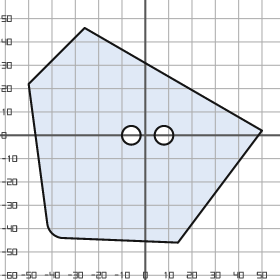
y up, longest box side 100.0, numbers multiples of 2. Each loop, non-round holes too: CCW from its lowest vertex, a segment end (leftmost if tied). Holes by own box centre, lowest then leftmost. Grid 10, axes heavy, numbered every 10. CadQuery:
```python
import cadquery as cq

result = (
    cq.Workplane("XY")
    .moveTo(14.0, -46.0)
    .lineTo(50.0, 2.0)
    .lineTo(-26.0, 46.0)
    .lineTo(-50.0, 22.0)
    .lineTo(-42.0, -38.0)
    .threePointArc((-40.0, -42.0), (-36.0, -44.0))
    .close()
    .moveTo(-6.0, 0.0)
    .circle(4.0)
    .moveTo(8.0, 0.0)
    .circle(4.0)
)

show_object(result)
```